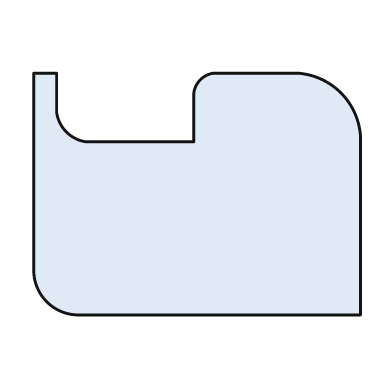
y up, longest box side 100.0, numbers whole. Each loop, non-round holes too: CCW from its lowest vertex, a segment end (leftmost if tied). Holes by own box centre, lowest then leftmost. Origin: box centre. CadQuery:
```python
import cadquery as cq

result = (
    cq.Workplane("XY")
    .moveTo(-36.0, -37.0)
    .lineTo(50.0, -37.0)
    .lineTo(50.0, 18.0)
    .threePointArc((44.0, 31.0), (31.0, 37.0))
    .lineTo(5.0, 37.0)
    .threePointArc((1.0, 35.0), (-1.0, 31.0))
    .lineTo(-1.0, 16.0)
    .lineTo(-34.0, 16.0)
    .threePointArc((-40.0, 19.0), (-43.0, 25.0))
    .lineTo(-43.0, 37.0)
    .lineTo(-50.0, 37.0)
    .lineTo(-50.0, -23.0)
    .threePointArc((-46.0, -33.0), (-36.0, -37.0))
    .close()
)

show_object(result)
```